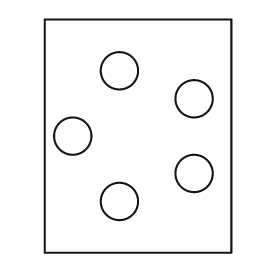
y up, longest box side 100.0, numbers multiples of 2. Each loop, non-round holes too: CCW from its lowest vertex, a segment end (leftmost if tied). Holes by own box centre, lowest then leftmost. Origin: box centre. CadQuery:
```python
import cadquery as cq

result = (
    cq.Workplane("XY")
    .moveTo(-40.0, -50.0)
    .lineTo(40.0, -50.0)
    .lineTo(40.0, 50.0)
    .lineTo(-40.0, 50.0)
    .close()
    .moveTo(-8.0, -28.0)
    .circle(8.0)
    .moveTo(24.0, -16.0)
    .circle(8.0)
    .moveTo(-28.0, 0.0)
    .circle(8.0)
    .moveTo(24.0, 16.0)
    .circle(8.0)
    .moveTo(-8.0, 28.0)
    .circle(8.0)
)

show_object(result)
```